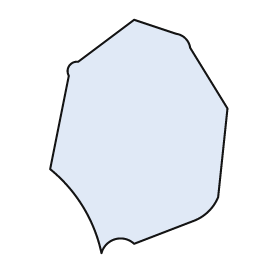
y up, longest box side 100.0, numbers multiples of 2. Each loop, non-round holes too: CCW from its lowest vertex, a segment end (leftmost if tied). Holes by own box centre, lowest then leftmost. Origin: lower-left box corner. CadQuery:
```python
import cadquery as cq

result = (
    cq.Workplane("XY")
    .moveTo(22.0, 0.0)
    .threePointArc((28.0, 6.0), (36.0, 4.0))
    .lineTo(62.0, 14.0)
    .threePointArc((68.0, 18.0), (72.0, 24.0))
    .lineTo(76.0, 62.0)
    .lineTo(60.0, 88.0)
    .threePointArc((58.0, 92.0), (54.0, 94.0))
    .lineTo(36.0, 100.0)
    .lineTo(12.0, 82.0)
    .threePointArc((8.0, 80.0), (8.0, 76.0))
    .lineTo(0.0, 36.0)
    .threePointArc((14.0, 20.0), (22.0, 0.0))
    .close()
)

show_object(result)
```